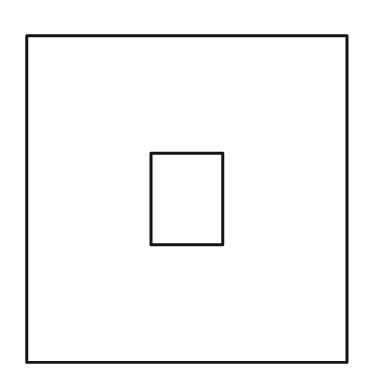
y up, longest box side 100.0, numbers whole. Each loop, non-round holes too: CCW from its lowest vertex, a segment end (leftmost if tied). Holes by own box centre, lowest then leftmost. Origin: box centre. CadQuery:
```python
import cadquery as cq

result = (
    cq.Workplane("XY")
    .moveTo(-49.0, -50.0)
    .lineTo(49.0, -50.0)
    .lineTo(49.0, 50.0)
    .lineTo(-49.0, 50.0)
    .close()
    .moveTo(-11.0, -14.0)
    .lineTo(11.0, -14.0)
    .lineTo(11.0, 14.0)
    .lineTo(-11.0, 14.0)
    .close()
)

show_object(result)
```